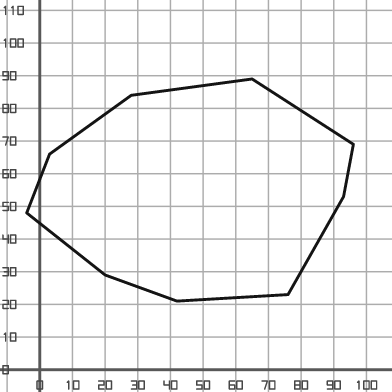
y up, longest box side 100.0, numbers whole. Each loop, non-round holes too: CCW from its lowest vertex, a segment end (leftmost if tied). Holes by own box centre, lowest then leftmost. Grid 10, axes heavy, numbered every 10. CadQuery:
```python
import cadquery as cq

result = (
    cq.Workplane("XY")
    .moveTo(42.0, 21.0)
    .lineTo(76.0, 23.0)
    .lineTo(93.0, 53.0)
    .lineTo(96.0, 69.0)
    .lineTo(65.0, 89.0)
    .lineTo(28.0, 84.0)
    .lineTo(3.0, 66.0)
    .lineTo(-4.0, 48.0)
    .lineTo(20.0, 29.0)
    .close()
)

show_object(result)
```